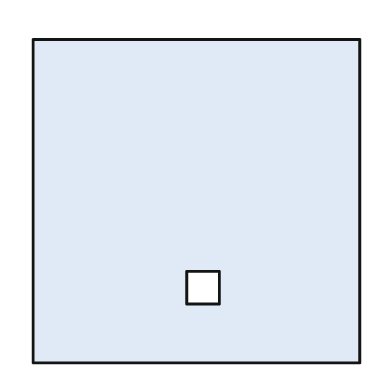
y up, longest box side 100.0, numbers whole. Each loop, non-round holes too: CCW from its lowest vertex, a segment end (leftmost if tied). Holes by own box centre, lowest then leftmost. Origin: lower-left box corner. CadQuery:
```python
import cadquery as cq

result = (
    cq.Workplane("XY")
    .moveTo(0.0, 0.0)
    .lineTo(100.0, 0.0)
    .lineTo(100.0, 99.0)
    .lineTo(0.0, 99.0)
    .close()
    .moveTo(47.0, 18.0)
    .lineTo(57.0, 18.0)
    .lineTo(57.0, 28.0)
    .lineTo(47.0, 28.0)
    .close()
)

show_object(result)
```